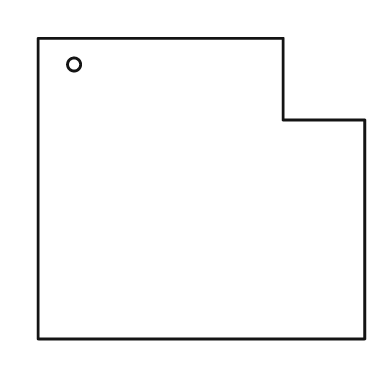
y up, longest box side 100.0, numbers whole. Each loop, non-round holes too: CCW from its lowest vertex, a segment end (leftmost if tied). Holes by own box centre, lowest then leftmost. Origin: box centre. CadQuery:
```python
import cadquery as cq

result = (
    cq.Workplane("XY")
    .moveTo(-50.0, -46.0)
    .lineTo(50.0, -46.0)
    .lineTo(50.0, 21.0)
    .lineTo(25.0, 21.0)
    .lineTo(25.0, 46.0)
    .lineTo(-50.0, 46.0)
    .close()
    .moveTo(-39.0, 38.0)
    .circle(2.0)
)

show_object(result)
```